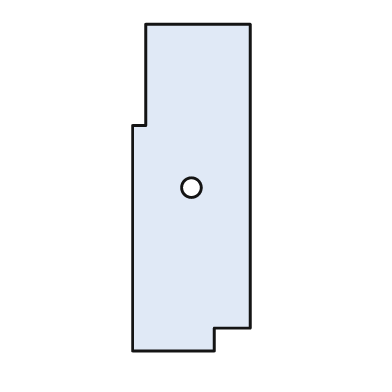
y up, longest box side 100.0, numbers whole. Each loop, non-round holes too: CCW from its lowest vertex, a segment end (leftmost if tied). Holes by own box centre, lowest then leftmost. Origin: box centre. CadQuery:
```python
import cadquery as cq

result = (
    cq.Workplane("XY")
    .moveTo(-18.0, -50.0)
    .lineTo(7.0, -50.0)
    .lineTo(7.0, -43.0)
    .lineTo(18.0, -43.0)
    .lineTo(18.0, 50.0)
    .lineTo(-14.0, 50.0)
    .lineTo(-14.0, 19.0)
    .lineTo(-18.0, 19.0)
    .close()
    .moveTo(0.0, 0.0)
    .circle(3.0)
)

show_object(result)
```